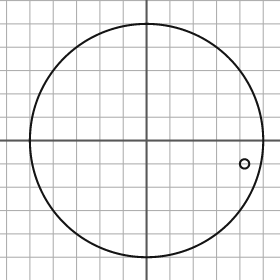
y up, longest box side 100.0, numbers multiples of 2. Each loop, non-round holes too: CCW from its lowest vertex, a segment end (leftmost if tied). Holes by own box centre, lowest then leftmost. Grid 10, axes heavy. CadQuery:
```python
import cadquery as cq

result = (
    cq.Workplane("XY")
    .moveTo(0.0, 0.0)
    .circle(50.0)
    .moveTo(42.0, -10.0)
    .circle(2.0)
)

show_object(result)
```